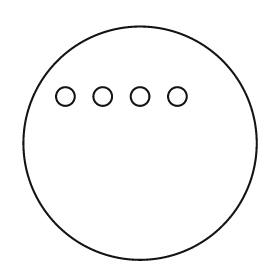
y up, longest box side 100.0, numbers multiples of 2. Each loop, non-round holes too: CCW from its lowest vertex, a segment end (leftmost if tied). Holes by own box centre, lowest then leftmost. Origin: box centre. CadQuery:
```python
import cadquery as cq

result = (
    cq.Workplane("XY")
    .moveTo(0.0, 0.0)
    .circle(50.0)
    .moveTo(-32.0, 20.0)
    .circle(4.0)
    .moveTo(-16.0, 20.0)
    .circle(4.0)
    .moveTo(0.0, 20.0)
    .circle(4.0)
    .moveTo(16.0, 20.0)
    .circle(4.0)
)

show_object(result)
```